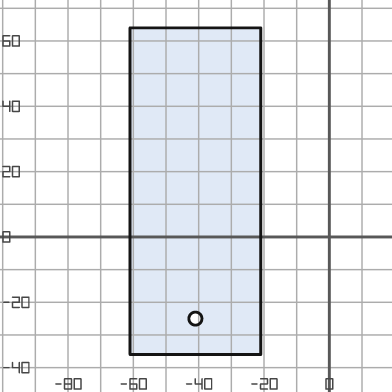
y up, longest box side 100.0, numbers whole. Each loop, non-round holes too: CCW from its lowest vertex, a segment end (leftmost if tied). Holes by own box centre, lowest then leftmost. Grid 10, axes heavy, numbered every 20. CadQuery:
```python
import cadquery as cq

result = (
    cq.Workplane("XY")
    .moveTo(-61.0, -36.0)
    .lineTo(-21.0, -36.0)
    .lineTo(-21.0, 64.0)
    .lineTo(-61.0, 64.0)
    .close()
    .moveTo(-41.0, -25.0)
    .circle(2.0)
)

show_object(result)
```